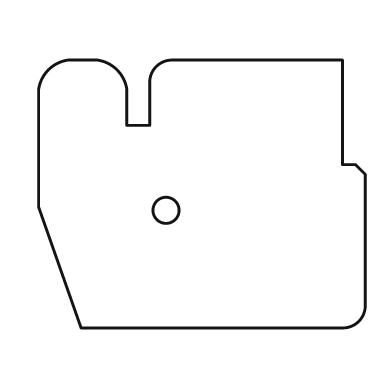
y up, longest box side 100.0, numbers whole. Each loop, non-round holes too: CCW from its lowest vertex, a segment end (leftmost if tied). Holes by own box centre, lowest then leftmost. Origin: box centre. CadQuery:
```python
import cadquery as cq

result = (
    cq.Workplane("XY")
    .moveTo(-37.0, -41.0)
    .lineTo(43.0, -41.0)
    .threePointArc((48.0, -39.0), (50.0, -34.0))
    .lineTo(50.0, 6.0)
    .lineTo(47.0, 9.0)
    .lineTo(43.0, 9.0)
    .lineTo(43.0, 41.0)
    .lineTo(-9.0, 41.0)
    .threePointArc((-14.0, 39.0), (-16.0, 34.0))
    .lineTo(-16.0, 21.0)
    .lineTo(-23.0, 21.0)
    .lineTo(-23.0, 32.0)
    .threePointArc((-26.0, 38.0), (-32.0, 41.0))
    .lineTo(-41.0, 41.0)
    .threePointArc((-47.0, 38.0), (-50.0, 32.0))
    .lineTo(-50.0, -4.0)
    .close()
    .moveTo(-11.0, -5.0)
    .circle(4.0)
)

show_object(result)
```